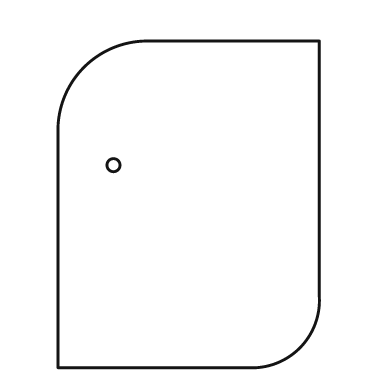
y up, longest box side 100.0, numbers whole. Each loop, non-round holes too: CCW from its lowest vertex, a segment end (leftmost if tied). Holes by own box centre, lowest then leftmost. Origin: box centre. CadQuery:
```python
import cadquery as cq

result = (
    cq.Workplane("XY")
    .moveTo(-40.0, -50.0)
    .lineTo(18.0, -50.0)
    .threePointArc((34.0, -44.0), (40.0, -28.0))
    .lineTo(40.0, 50.0)
    .lineTo(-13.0, 50.0)
    .threePointArc((-32.0, 42.0), (-40.0, 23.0))
    .close()
    .moveTo(-23.0, 12.0)
    .circle(2.0)
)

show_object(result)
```